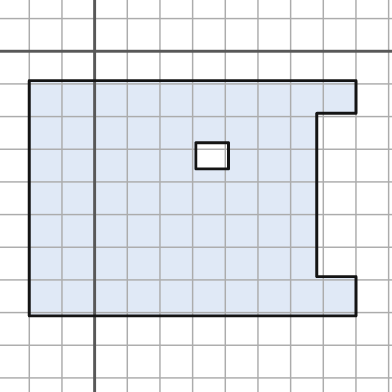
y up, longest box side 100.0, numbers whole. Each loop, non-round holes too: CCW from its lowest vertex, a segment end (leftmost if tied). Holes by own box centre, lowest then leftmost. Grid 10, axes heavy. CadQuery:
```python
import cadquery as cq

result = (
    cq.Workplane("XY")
    .moveTo(-20.0, -81.0)
    .lineTo(80.0, -81.0)
    .lineTo(80.0, -69.0)
    .lineTo(68.0, -69.0)
    .lineTo(68.0, -19.0)
    .lineTo(80.0, -19.0)
    .lineTo(80.0, -9.0)
    .lineTo(-20.0, -9.0)
    .close()
    .moveTo(31.0, -36.0)
    .lineTo(41.0, -36.0)
    .lineTo(41.0, -28.0)
    .lineTo(31.0, -28.0)
    .close()
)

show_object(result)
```